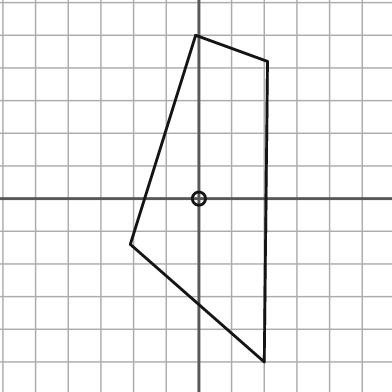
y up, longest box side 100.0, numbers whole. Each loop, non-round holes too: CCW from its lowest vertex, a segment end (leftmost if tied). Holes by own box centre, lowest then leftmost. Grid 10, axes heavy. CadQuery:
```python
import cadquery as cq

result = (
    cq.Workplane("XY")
    .moveTo(20.0, -50.0)
    .lineTo(21.0, 42.0)
    .lineTo(-1.0, 50.0)
    .lineTo(-21.0, -14.0)
    .close()
    .moveTo(0.0, 0.0)
    .circle(2.0)
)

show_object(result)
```